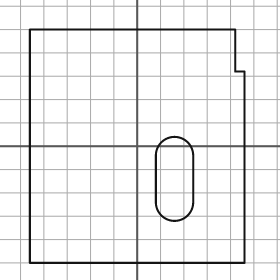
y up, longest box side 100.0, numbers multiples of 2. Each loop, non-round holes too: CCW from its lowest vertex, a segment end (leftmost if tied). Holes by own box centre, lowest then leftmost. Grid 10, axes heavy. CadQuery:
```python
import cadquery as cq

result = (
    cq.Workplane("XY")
    .moveTo(-46.0, -50.0)
    .lineTo(46.0, -50.0)
    .lineTo(46.0, 32.0)
    .lineTo(42.0, 32.0)
    .lineTo(42.0, 50.0)
    .lineTo(-46.0, 50.0)
    .close()
    .moveTo(8.0, -24.0)
    .threePointArc((16.0, -32.0), (24.0, -24.0))
    .lineTo(24.0, -4.0)
    .threePointArc((16.0, 4.0), (8.0, -4.0))
    .close()
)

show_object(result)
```